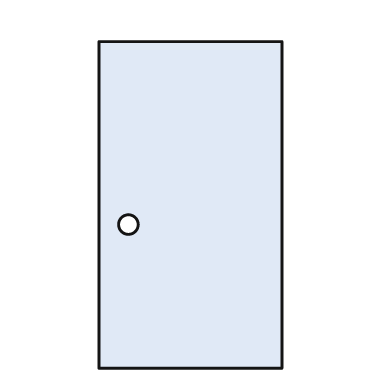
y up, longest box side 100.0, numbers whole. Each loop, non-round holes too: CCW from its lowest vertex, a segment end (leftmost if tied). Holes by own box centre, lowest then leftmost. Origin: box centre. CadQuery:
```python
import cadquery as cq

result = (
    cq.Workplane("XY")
    .moveTo(-28.0, -50.0)
    .lineTo(28.0, -50.0)
    .lineTo(28.0, 50.0)
    .lineTo(-28.0, 50.0)
    .close()
    .moveTo(-19.0, -6.0)
    .circle(3.0)
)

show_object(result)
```